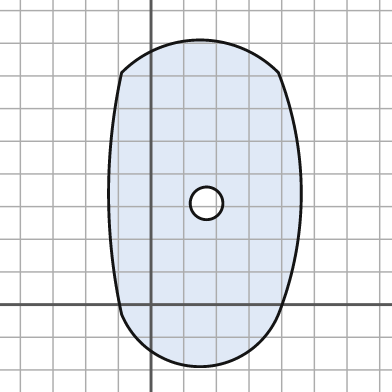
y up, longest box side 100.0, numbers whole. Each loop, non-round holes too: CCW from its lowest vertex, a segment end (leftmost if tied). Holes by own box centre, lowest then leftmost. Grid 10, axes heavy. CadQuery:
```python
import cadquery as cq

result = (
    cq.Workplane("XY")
    .moveTo(-9.0, -3.0)
    .threePointArc((15.0, -19.0), (39.0, -3.0))
    .threePointArc((46.0, 34.0), (39.0, 71.0))
    .threePointArc((15.0, 81.0), (-9.0, 71.0))
    .threePointArc((-13.0, 34.0), (-9.0, -3.0))
    .close()
    .moveTo(17.0, 31.0)
    .circle(5.0)
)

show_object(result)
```